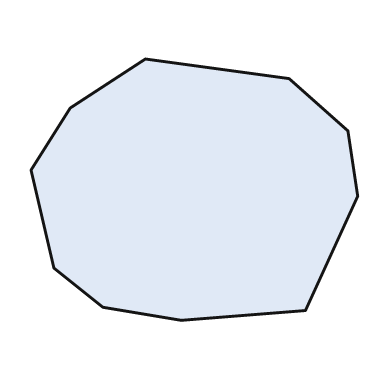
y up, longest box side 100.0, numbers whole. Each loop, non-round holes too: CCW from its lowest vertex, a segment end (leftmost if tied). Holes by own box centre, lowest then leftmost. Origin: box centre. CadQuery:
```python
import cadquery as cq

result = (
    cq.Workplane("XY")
    .moveTo(-4.0, -40.0)
    .lineTo(34.0, -37.0)
    .lineTo(50.0, -2.0)
    .lineTo(47.0, 18.0)
    .lineTo(29.0, 34.0)
    .lineTo(-15.0, 40.0)
    .lineTo(-38.0, 25.0)
    .lineTo(-50.0, 6.0)
    .lineTo(-43.0, -24.0)
    .lineTo(-28.0, -36.0)
    .close()
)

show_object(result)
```